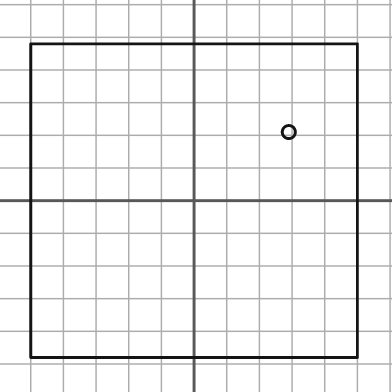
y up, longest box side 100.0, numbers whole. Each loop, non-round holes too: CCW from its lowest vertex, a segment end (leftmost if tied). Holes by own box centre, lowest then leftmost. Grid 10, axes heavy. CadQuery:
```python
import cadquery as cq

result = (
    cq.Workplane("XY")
    .moveTo(-50.0, -48.0)
    .lineTo(50.0, -48.0)
    .lineTo(50.0, 48.0)
    .lineTo(-50.0, 48.0)
    .close()
    .moveTo(29.0, 21.0)
    .circle(2.0)
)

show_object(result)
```